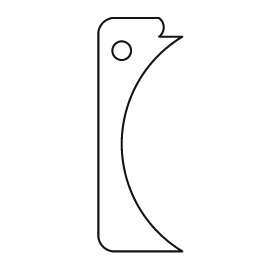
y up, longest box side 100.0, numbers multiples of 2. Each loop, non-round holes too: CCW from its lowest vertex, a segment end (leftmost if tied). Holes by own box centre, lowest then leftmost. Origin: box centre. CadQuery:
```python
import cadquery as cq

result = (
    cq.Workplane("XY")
    .moveTo(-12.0, -50.0)
    .lineTo(18.0, -50.0)
    .threePointArc((-8.0, -4.0), (18.0, 42.0))
    .lineTo(8.0, 42.0)
    .threePointArc((10.0, 46.0), (8.0, 50.0))
    .lineTo(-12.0, 50.0)
    .threePointArc((-16.0, 48.0), (-18.0, 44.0))
    .lineTo(-18.0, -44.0)
    .threePointArc((-16.0, -48.0), (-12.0, -50.0))
    .close()
    .moveTo(-8.0, 36.0)
    .circle(4.0)
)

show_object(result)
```